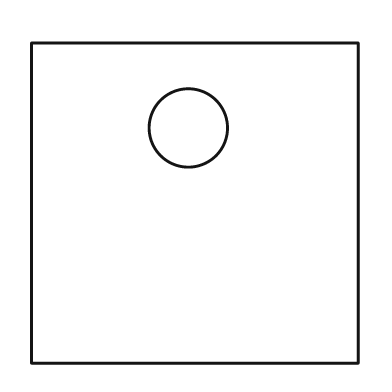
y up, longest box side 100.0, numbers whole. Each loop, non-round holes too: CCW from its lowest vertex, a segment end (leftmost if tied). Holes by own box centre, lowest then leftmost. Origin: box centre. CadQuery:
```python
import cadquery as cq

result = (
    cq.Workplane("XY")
    .moveTo(-50.0, -49.0)
    .lineTo(50.0, -49.0)
    .lineTo(50.0, 49.0)
    .lineTo(-50.0, 49.0)
    .close()
    .moveTo(-2.0, 23.0)
    .circle(12.0)
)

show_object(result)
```